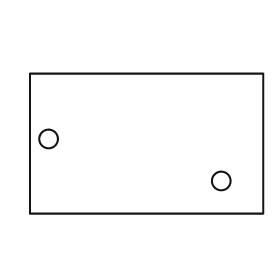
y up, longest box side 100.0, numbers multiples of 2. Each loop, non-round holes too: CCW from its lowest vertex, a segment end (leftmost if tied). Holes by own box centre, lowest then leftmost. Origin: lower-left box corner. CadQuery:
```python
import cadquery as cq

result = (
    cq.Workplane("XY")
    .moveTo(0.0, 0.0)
    .lineTo(100.0, 0.0)
    .lineTo(100.0, 60.0)
    .lineTo(0.0, 60.0)
    .close()
    .moveTo(82.0, 14.0)
    .circle(4.0)
    .moveTo(8.0, 32.0)
    .circle(4.0)
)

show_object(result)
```